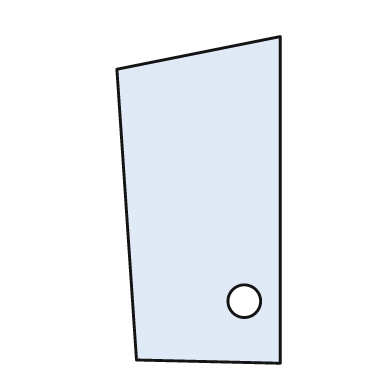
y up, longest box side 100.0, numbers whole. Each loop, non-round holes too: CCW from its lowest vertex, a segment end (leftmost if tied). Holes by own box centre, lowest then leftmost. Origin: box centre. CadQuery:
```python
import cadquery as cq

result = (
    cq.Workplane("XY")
    .moveTo(25.0, -50.0)
    .lineTo(25.0, 50.0)
    .lineTo(-25.0, 40.0)
    .lineTo(-19.0, -49.0)
    .close()
    .moveTo(14.0, -31.0)
    .circle(5.0)
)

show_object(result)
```